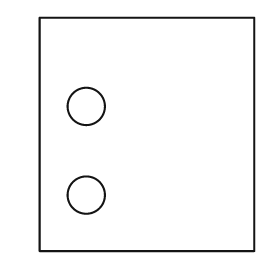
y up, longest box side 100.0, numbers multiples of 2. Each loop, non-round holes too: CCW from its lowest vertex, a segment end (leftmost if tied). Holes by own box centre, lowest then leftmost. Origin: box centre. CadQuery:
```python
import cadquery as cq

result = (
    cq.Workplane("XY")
    .moveTo(-46.0, -50.0)
    .lineTo(46.0, -50.0)
    .lineTo(46.0, 50.0)
    .lineTo(-46.0, 50.0)
    .close()
    .moveTo(-26.0, -26.0)
    .circle(8.0)
    .moveTo(-26.0, 12.0)
    .circle(8.0)
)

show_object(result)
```